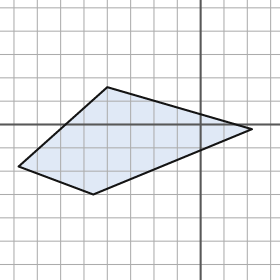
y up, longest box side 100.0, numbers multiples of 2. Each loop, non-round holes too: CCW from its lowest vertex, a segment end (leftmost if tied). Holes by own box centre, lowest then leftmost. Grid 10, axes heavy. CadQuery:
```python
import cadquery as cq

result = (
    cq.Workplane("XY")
    .moveTo(-46.0, -30.0)
    .lineTo(22.0, -2.0)
    .lineTo(-40.0, 16.0)
    .lineTo(-78.0, -18.0)
    .close()
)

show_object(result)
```